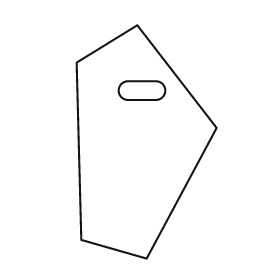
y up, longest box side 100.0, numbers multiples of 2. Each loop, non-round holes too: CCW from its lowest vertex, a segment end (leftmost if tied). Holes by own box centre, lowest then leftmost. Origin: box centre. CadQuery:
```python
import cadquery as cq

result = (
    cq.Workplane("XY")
    .moveTo(0.0, -50.0)
    .lineTo(30.0, 6.0)
    .lineTo(-4.0, 50.0)
    .lineTo(-30.0, 34.0)
    .lineTo(-28.0, -42.0)
    .close()
    .moveTo(-8.0, 18.0)
    .lineTo(4.0, 18.0)
    .threePointArc((8.0, 22.0), (4.0, 26.0))
    .lineTo(-8.0, 26.0)
    .threePointArc((-12.0, 22.0), (-8.0, 18.0))
    .close()
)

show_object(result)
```